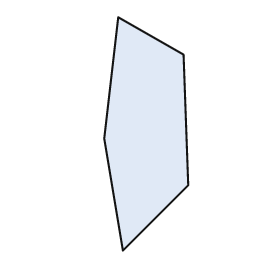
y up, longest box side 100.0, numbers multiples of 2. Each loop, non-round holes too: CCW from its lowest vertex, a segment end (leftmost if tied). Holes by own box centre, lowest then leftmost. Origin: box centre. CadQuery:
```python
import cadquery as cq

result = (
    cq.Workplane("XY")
    .moveTo(-10.0, -50.0)
    .lineTo(18.0, -22.0)
    .lineTo(16.0, 34.0)
    .lineTo(-12.0, 50.0)
    .lineTo(-18.0, -2.0)
    .close()
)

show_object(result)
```